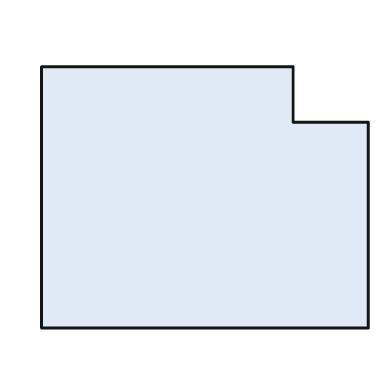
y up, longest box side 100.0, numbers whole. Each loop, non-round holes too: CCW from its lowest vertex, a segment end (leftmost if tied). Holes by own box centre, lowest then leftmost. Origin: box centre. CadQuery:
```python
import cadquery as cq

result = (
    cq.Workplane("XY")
    .moveTo(-50.0, -40.0)
    .lineTo(50.0, -40.0)
    .lineTo(50.0, 23.0)
    .lineTo(27.0, 23.0)
    .lineTo(27.0, 40.0)
    .lineTo(-50.0, 40.0)
    .close()
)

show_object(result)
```